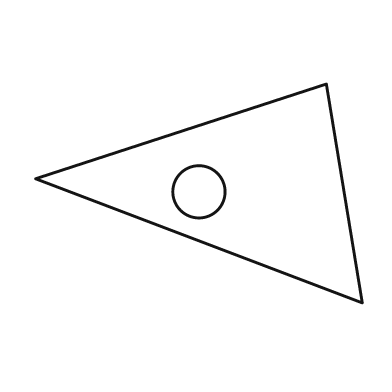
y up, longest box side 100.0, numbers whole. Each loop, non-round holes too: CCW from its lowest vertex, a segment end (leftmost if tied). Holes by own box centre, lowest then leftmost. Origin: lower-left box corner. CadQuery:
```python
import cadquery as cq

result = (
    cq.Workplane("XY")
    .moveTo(100.0, 0.0)
    .lineTo(89.0, 67.0)
    .lineTo(0.0, 38.0)
    .close()
    .moveTo(50.0, 34.0)
    .circle(8.0)
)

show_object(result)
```